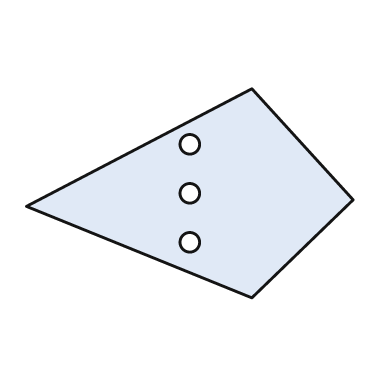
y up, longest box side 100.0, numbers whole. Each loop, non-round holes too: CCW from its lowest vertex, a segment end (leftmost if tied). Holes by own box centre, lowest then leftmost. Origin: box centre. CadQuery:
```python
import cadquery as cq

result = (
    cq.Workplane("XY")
    .moveTo(19.0, -32.0)
    .lineTo(50.0, -2.0)
    .lineTo(19.0, 32.0)
    .lineTo(-50.0, -4.0)
    .close()
    .moveTo(0.0, -15.0)
    .circle(3.0)
    .moveTo(0.0, 0.0)
    .circle(3.0)
    .moveTo(0.0, 15.0)
    .circle(3.0)
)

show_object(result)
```